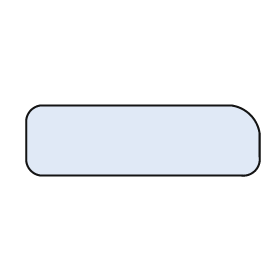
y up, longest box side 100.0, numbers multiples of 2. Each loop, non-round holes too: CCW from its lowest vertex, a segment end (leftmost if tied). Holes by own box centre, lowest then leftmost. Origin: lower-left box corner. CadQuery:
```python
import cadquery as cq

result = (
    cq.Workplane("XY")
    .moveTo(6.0, 0.0)
    .lineTo(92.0, 0.0)
    .threePointArc((98.0, 2.0), (100.0, 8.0))
    .lineTo(100.0, 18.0)
    .threePointArc((96.0, 26.0), (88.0, 30.0))
    .lineTo(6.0, 30.0)
    .threePointArc((2.0, 28.0), (0.0, 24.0))
    .lineTo(0.0, 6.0)
    .threePointArc((2.0, 2.0), (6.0, 0.0))
    .close()
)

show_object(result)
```